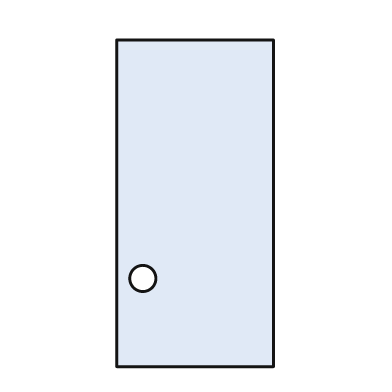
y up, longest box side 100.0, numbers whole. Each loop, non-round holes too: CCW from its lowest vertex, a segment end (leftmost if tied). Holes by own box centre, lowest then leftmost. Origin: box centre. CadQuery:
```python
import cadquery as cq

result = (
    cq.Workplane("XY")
    .moveTo(-24.0, -50.0)
    .lineTo(24.0, -50.0)
    .lineTo(24.0, 50.0)
    .lineTo(-24.0, 50.0)
    .close()
    .moveTo(-16.0, -23.0)
    .circle(4.0)
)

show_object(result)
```